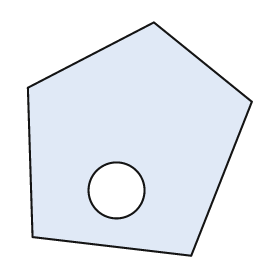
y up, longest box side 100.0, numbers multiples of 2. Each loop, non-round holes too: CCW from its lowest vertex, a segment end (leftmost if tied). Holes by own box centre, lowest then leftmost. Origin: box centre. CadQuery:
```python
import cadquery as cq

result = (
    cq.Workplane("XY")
    .moveTo(22.0, -50.0)
    .lineTo(48.0, 16.0)
    .lineTo(6.0, 50.0)
    .lineTo(-48.0, 22.0)
    .lineTo(-46.0, -42.0)
    .close()
    .moveTo(-10.0, -22.0)
    .circle(12.0)
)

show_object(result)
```